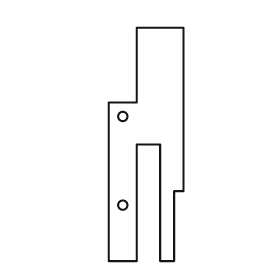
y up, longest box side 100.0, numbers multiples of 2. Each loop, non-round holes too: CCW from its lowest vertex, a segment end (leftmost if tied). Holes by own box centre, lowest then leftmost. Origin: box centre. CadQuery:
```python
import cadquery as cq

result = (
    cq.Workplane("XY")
    .moveTo(-16.0, -50.0)
    .lineTo(-4.0, -50.0)
    .lineTo(-4.0, 0.0)
    .lineTo(6.0, 0.0)
    .lineTo(6.0, -50.0)
    .lineTo(12.0, -50.0)
    .lineTo(12.0, -20.0)
    .lineTo(16.0, -20.0)
    .lineTo(16.0, 50.0)
    .lineTo(-4.0, 50.0)
    .lineTo(-4.0, 18.0)
    .lineTo(-16.0, 18.0)
    .close()
    .moveTo(-10.0, -26.0)
    .circle(2.0)
    .moveTo(-10.0, 12.0)
    .circle(2.0)
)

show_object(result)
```